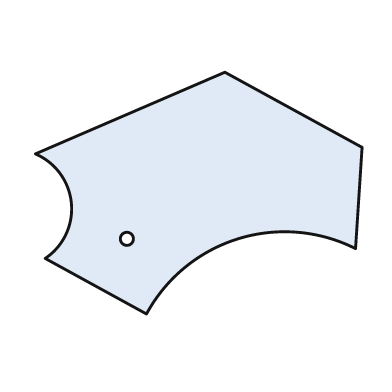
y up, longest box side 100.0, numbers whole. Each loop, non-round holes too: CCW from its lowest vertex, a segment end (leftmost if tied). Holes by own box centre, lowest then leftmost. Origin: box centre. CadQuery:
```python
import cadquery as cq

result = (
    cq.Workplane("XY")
    .moveTo(-16.0, -37.0)
    .threePointArc((12.0, -14.0), (48.0, -17.0))
    .lineTo(50.0, 14.0)
    .lineTo(8.0, 37.0)
    .lineTo(-50.0, 12.0)
    .threePointArc((-39.0, -3.0), (-47.0, -20.0))
    .close()
    .moveTo(-22.0, -14.0)
    .circle(2.0)
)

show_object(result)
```